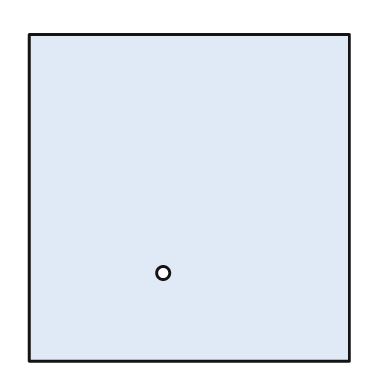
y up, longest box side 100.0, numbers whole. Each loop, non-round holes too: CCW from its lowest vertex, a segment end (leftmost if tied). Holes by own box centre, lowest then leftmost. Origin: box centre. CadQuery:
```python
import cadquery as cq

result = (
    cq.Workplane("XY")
    .moveTo(-49.0, -50.0)
    .lineTo(49.0, -50.0)
    .lineTo(49.0, 50.0)
    .lineTo(-49.0, 50.0)
    .close()
    .moveTo(-8.0, -23.0)
    .circle(2.0)
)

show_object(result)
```